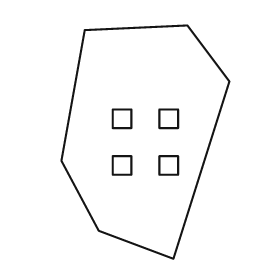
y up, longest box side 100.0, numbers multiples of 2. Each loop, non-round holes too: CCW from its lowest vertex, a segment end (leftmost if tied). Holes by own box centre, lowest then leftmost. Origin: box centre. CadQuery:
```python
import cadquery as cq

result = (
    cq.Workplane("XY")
    .moveTo(12.0, -50.0)
    .lineTo(36.0, 26.0)
    .lineTo(18.0, 50.0)
    .lineTo(-26.0, 48.0)
    .lineTo(-36.0, -8.0)
    .lineTo(-20.0, -38.0)
    .close()
    .moveTo(-14.0, -14.0)
    .lineTo(-6.0, -14.0)
    .lineTo(-6.0, -6.0)
    .lineTo(-14.0, -6.0)
    .close()
    .moveTo(6.0, -14.0)
    .lineTo(14.0, -14.0)
    .lineTo(14.0, -6.0)
    .lineTo(6.0, -6.0)
    .close()
    .moveTo(-14.0, 6.0)
    .lineTo(-6.0, 6.0)
    .lineTo(-6.0, 14.0)
    .lineTo(-14.0, 14.0)
    .close()
    .moveTo(6.0, 6.0)
    .lineTo(14.0, 6.0)
    .lineTo(14.0, 14.0)
    .lineTo(6.0, 14.0)
    .close()
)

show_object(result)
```